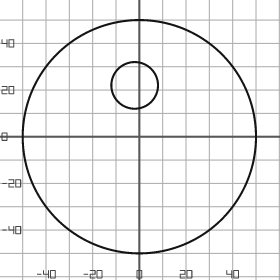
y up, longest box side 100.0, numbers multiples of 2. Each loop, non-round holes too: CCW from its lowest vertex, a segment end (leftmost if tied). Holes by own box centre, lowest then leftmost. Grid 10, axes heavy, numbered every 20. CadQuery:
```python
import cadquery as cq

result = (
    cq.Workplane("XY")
    .moveTo(0.0, 0.0)
    .circle(50.0)
    .moveTo(-2.0, 22.0)
    .circle(10.0)
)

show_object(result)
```